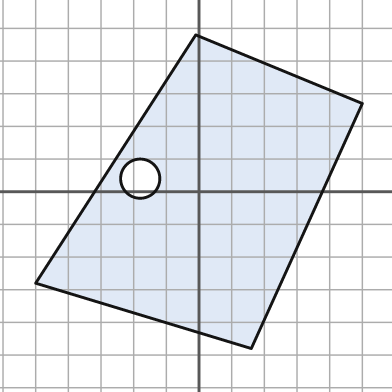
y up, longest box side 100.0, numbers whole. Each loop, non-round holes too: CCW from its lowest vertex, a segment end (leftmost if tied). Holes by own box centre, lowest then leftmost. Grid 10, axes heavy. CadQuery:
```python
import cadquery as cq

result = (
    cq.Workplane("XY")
    .moveTo(16.0, -48.0)
    .lineTo(50.0, 27.0)
    .lineTo(-1.0, 48.0)
    .lineTo(-50.0, -28.0)
    .close()
    .moveTo(-18.0, 4.0)
    .circle(6.0)
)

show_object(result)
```